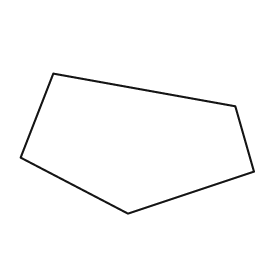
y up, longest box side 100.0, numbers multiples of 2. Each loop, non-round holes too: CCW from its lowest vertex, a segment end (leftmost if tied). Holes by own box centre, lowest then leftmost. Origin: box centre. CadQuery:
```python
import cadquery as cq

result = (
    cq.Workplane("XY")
    .moveTo(-4.0, -30.0)
    .lineTo(50.0, -12.0)
    .lineTo(42.0, 16.0)
    .lineTo(-36.0, 30.0)
    .lineTo(-50.0, -6.0)
    .close()
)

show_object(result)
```